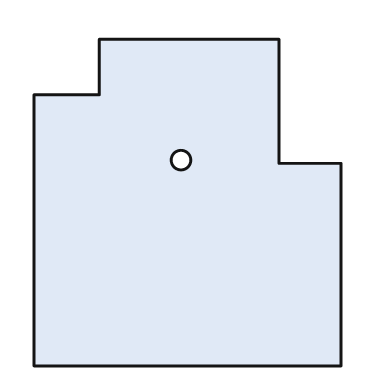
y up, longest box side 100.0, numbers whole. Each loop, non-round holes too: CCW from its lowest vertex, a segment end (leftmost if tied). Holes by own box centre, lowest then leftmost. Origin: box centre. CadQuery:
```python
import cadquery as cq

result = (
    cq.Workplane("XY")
    .moveTo(-47.0, -50.0)
    .lineTo(47.0, -50.0)
    .lineTo(47.0, 12.0)
    .lineTo(28.0, 12.0)
    .lineTo(28.0, 50.0)
    .lineTo(-27.0, 50.0)
    .lineTo(-27.0, 33.0)
    .lineTo(-47.0, 33.0)
    .close()
    .moveTo(-2.0, 13.0)
    .circle(3.0)
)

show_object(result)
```